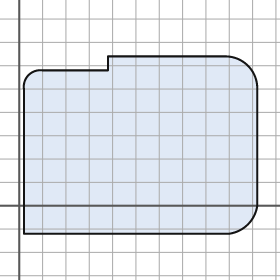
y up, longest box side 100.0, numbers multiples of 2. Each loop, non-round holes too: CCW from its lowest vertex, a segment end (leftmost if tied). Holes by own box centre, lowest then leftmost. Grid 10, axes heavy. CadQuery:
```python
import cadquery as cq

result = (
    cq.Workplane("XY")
    .moveTo(2.0, -12.0)
    .lineTo(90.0, -12.0)
    .threePointArc((98.0, -8.0), (102.0, 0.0))
    .lineTo(102.0, 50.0)
    .threePointArc((98.0, 60.0), (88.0, 64.0))
    .lineTo(38.0, 64.0)
    .lineTo(38.0, 58.0)
    .lineTo(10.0, 58.0)
    .threePointArc((4.0, 56.0), (2.0, 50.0))
    .close()
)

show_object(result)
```